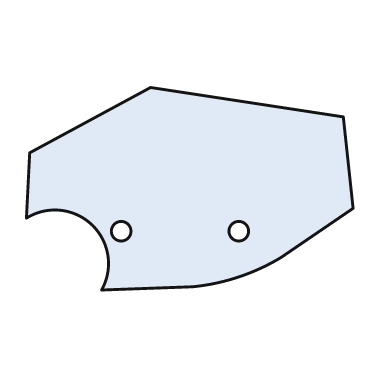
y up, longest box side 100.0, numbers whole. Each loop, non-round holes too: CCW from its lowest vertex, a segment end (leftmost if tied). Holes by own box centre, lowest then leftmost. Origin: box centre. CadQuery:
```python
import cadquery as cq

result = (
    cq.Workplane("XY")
    .moveTo(-27.0, -31.0)
    .lineTo(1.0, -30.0)
    .threePointArc((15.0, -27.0), (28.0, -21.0))
    .lineTo(50.0, -6.0)
    .lineTo(47.0, 22.0)
    .lineTo(-12.0, 31.0)
    .lineTo(-49.0, 11.0)
    .lineTo(-50.0, -9.0)
    .threePointArc((-30.0, -11.0), (-27.0, -31.0))
    .close()
    .moveTo(-21.0, -13.0)
    .circle(3.0)
    .moveTo(15.0, -13.0)
    .circle(3.0)
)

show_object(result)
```